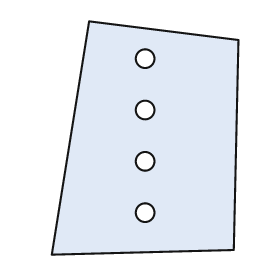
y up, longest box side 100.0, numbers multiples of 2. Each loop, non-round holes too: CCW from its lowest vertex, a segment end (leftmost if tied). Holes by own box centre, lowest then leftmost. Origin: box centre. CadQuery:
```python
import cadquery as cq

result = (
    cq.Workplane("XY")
    .moveTo(-40.0, -50.0)
    .lineTo(38.0, -48.0)
    .lineTo(40.0, 42.0)
    .lineTo(-24.0, 50.0)
    .close()
    .moveTo(0.0, -32.0)
    .circle(4.0)
    .moveTo(0.0, -10.0)
    .circle(4.0)
    .moveTo(0.0, 12.0)
    .circle(4.0)
    .moveTo(0.0, 34.0)
    .circle(4.0)
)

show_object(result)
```